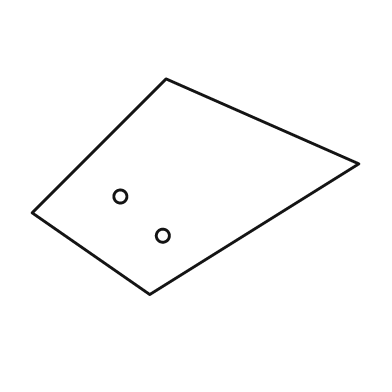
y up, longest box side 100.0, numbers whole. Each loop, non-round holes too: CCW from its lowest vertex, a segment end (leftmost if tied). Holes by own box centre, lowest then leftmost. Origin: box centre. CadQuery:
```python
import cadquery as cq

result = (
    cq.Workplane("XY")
    .moveTo(-14.0, -33.0)
    .lineTo(50.0, 7.0)
    .lineTo(-9.0, 33.0)
    .lineTo(-50.0, -8.0)
    .close()
    .moveTo(-10.0, -15.0)
    .circle(2.0)
    .moveTo(-23.0, -3.0)
    .circle(2.0)
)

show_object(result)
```